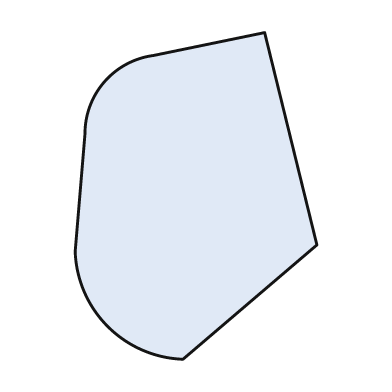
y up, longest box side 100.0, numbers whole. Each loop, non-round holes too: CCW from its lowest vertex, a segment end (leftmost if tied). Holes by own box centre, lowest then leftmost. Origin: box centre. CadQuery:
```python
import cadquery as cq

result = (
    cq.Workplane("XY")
    .moveTo(-4.0, -50.0)
    .lineTo(37.0, -15.0)
    .lineTo(21.0, 50.0)
    .lineTo(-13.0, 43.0)
    .threePointArc((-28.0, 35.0), (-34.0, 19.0))
    .lineTo(-37.0, -17.0)
    .threePointArc((-27.0, -40.0), (-4.0, -50.0))
    .close()
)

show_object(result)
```